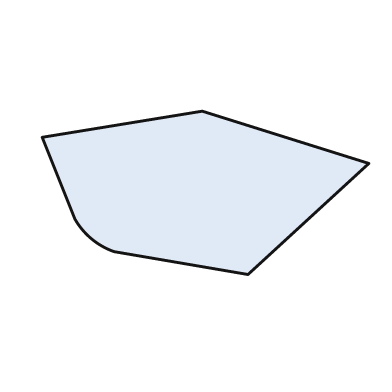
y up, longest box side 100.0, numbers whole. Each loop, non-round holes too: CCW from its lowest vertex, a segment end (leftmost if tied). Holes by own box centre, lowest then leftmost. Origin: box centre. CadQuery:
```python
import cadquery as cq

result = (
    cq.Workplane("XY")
    .moveTo(13.0, -25.0)
    .lineTo(50.0, 9.0)
    .lineTo(-1.0, 25.0)
    .lineTo(-50.0, 17.0)
    .lineTo(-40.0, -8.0)
    .threePointArc((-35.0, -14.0), (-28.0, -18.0))
    .close()
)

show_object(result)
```